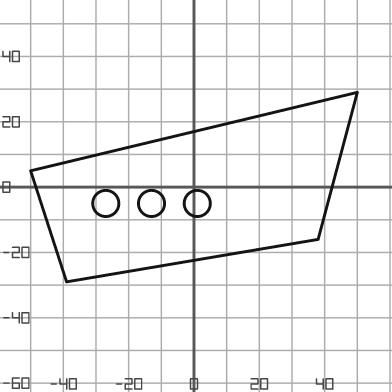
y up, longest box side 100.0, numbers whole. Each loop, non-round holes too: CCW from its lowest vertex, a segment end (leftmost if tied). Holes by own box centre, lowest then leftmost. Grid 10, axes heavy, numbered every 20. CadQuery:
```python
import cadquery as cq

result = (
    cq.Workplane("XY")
    .moveTo(-39.0, -29.0)
    .lineTo(38.0, -16.0)
    .lineTo(50.0, 29.0)
    .lineTo(-50.0, 5.0)
    .close()
    .moveTo(-27.0, -5.0)
    .circle(4.0)
    .moveTo(-13.0, -5.0)
    .circle(4.0)
    .moveTo(1.0, -5.0)
    .circle(4.0)
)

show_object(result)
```